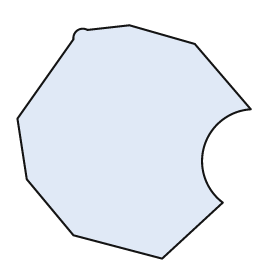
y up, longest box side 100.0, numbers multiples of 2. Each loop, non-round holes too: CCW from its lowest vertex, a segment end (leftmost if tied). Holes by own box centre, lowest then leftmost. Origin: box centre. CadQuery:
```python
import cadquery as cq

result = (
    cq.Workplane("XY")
    .moveTo(12.0, -50.0)
    .lineTo(38.0, -26.0)
    .threePointArc((30.0, -2.0), (50.0, 14.0))
    .lineTo(26.0, 42.0)
    .lineTo(-2.0, 50.0)
    .lineTo(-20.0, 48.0)
    .threePointArc((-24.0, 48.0), (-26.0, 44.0))
    .lineTo(-50.0, 10.0)
    .lineTo(-46.0, -16.0)
    .lineTo(-26.0, -40.0)
    .close()
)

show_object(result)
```